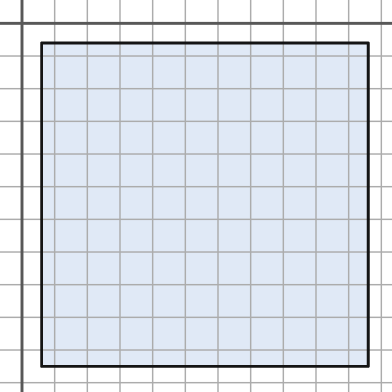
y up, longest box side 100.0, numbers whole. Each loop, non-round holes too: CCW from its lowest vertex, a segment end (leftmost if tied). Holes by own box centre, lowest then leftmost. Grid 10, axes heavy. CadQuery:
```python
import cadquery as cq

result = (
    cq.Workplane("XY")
    .moveTo(6.0, -105.0)
    .lineTo(106.0, -105.0)
    .lineTo(106.0, -6.0)
    .lineTo(6.0, -6.0)
    .close()
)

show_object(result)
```